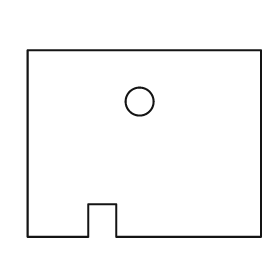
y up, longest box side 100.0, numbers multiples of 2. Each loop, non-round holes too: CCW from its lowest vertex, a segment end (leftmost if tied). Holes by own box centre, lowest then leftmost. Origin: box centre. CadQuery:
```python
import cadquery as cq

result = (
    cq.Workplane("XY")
    .moveTo(-50.0, -40.0)
    .lineTo(-24.0, -40.0)
    .lineTo(-24.0, -26.0)
    .lineTo(-12.0, -26.0)
    .lineTo(-12.0, -40.0)
    .lineTo(50.0, -40.0)
    .lineTo(50.0, 40.0)
    .lineTo(-50.0, 40.0)
    .close()
    .moveTo(-2.0, 18.0)
    .circle(6.0)
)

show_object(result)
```